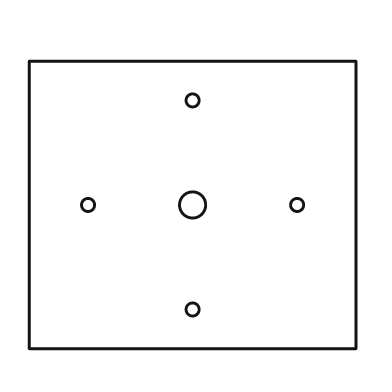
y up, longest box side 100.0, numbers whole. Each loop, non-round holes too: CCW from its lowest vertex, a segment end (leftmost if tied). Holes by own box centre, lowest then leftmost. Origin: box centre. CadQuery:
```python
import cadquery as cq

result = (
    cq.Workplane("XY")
    .moveTo(-50.0, -44.0)
    .lineTo(50.0, -44.0)
    .lineTo(50.0, 44.0)
    .lineTo(-50.0, 44.0)
    .close()
    .moveTo(0.0, -32.0)
    .circle(2.0)
    .moveTo(-32.0, 0.0)
    .circle(2.0)
    .moveTo(0.0, 0.0)
    .circle(4.0)
    .moveTo(32.0, 0.0)
    .circle(2.0)
    .moveTo(0.0, 32.0)
    .circle(2.0)
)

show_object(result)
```